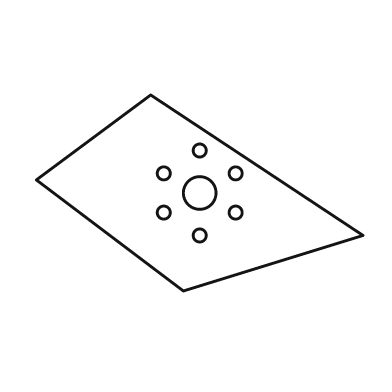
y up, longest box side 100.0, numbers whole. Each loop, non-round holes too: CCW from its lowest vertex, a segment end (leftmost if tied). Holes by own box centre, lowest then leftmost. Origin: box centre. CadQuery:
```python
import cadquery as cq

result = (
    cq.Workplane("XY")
    .moveTo(-5.0, -30.0)
    .lineTo(50.0, -13.0)
    .lineTo(-15.0, 30.0)
    .lineTo(-50.0, 4.0)
    .close()
    .moveTo(0.0, -13.0)
    .circle(2.0)
    .moveTo(-11.0, -6.0)
    .circle(2.0)
    .moveTo(11.0, -6.0)
    .circle(2.0)
    .moveTo(0.0, 0.0)
    .circle(5.0)
    .moveTo(-11.0, 6.0)
    .circle(2.0)
    .moveTo(11.0, 6.0)
    .circle(2.0)
    .moveTo(0.0, 13.0)
    .circle(2.0)
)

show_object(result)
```